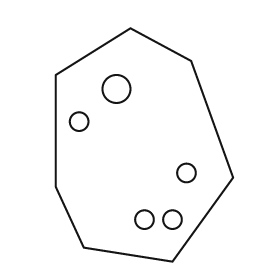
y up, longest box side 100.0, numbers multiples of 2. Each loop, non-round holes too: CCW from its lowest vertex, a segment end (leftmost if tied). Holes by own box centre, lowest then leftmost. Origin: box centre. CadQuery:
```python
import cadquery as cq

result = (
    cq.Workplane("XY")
    .moveTo(12.0, -50.0)
    .lineTo(38.0, -14.0)
    .lineTo(20.0, 36.0)
    .lineTo(-6.0, 50.0)
    .lineTo(-38.0, 30.0)
    .lineTo(-38.0, -18.0)
    .lineTo(-26.0, -44.0)
    .close()
    .moveTo(0.0, -32.0)
    .circle(4.0)
    .moveTo(12.0, -32.0)
    .circle(4.0)
    .moveTo(18.0, -12.0)
    .circle(4.0)
    .moveTo(-28.0, 10.0)
    .circle(4.0)
    .moveTo(-12.0, 24.0)
    .circle(6.0)
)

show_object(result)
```